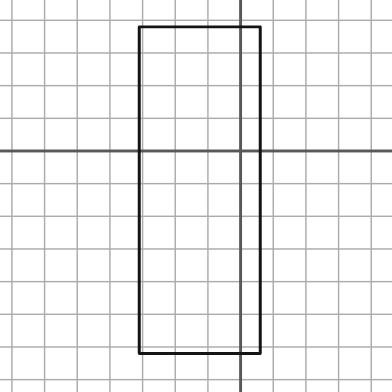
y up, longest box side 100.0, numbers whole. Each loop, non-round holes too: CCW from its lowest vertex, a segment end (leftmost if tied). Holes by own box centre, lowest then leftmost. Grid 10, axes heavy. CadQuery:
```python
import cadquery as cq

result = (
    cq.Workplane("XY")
    .moveTo(-31.0, -62.0)
    .lineTo(6.0, -62.0)
    .lineTo(6.0, 38.0)
    .lineTo(-31.0, 38.0)
    .close()
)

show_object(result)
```